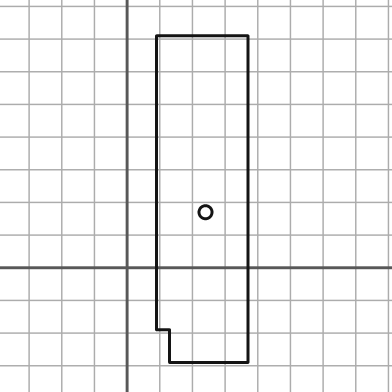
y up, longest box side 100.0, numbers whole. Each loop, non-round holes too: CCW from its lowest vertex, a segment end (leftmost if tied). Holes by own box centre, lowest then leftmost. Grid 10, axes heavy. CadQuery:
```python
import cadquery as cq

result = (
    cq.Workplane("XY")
    .moveTo(13.0, -29.0)
    .lineTo(37.0, -29.0)
    .lineTo(37.0, 71.0)
    .lineTo(9.0, 71.0)
    .lineTo(9.0, -19.0)
    .lineTo(13.0, -19.0)
    .close()
    .moveTo(24.0, 17.0)
    .circle(2.0)
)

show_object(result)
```